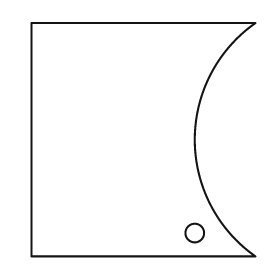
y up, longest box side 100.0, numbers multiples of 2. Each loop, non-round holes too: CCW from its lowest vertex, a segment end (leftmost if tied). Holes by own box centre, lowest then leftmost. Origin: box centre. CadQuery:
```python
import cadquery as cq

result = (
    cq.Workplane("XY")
    .moveTo(-48.0, -50.0)
    .lineTo(48.0, -50.0)
    .threePointArc((22.0, 0.0), (48.0, 50.0))
    .lineTo(-48.0, 50.0)
    .close()
    .moveTo(22.0, -40.0)
    .circle(4.0)
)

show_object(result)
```